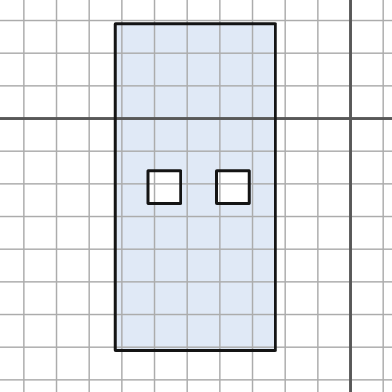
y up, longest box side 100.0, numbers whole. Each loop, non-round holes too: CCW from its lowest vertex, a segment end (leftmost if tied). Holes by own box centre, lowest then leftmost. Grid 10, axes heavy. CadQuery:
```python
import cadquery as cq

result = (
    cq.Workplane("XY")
    .moveTo(-72.0, -71.0)
    .lineTo(-23.0, -71.0)
    .lineTo(-23.0, 29.0)
    .lineTo(-72.0, 29.0)
    .close()
    .moveTo(-62.0, -26.0)
    .lineTo(-52.0, -26.0)
    .lineTo(-52.0, -16.0)
    .lineTo(-62.0, -16.0)
    .close()
    .moveTo(-41.0, -26.0)
    .lineTo(-31.0, -26.0)
    .lineTo(-31.0, -16.0)
    .lineTo(-41.0, -16.0)
    .close()
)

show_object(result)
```